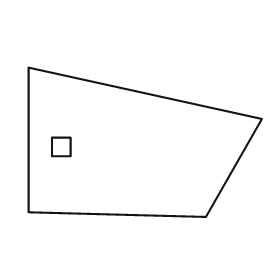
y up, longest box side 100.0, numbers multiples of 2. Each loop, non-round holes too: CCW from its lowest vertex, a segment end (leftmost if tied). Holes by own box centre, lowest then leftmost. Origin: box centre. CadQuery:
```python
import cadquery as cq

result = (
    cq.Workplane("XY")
    .moveTo(26.0, -32.0)
    .lineTo(50.0, 10.0)
    .lineTo(-50.0, 32.0)
    .lineTo(-50.0, -30.0)
    .close()
    .moveTo(-40.0, -6.0)
    .lineTo(-32.0, -6.0)
    .lineTo(-32.0, 2.0)
    .lineTo(-40.0, 2.0)
    .close()
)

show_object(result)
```